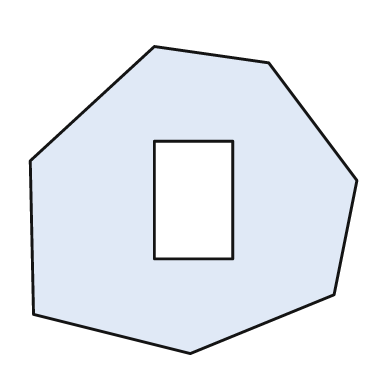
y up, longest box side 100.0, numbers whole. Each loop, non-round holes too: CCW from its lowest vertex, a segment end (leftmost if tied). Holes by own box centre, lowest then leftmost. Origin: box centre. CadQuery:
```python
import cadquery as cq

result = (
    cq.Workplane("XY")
    .moveTo(-1.0, -47.0)
    .lineTo(43.0, -29.0)
    .lineTo(50.0, 6.0)
    .lineTo(23.0, 42.0)
    .lineTo(-12.0, 47.0)
    .lineTo(-50.0, 12.0)
    .lineTo(-49.0, -35.0)
    .close()
    .moveTo(-12.0, -18.0)
    .lineTo(12.0, -18.0)
    .lineTo(12.0, 18.0)
    .lineTo(-12.0, 18.0)
    .close()
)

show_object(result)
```